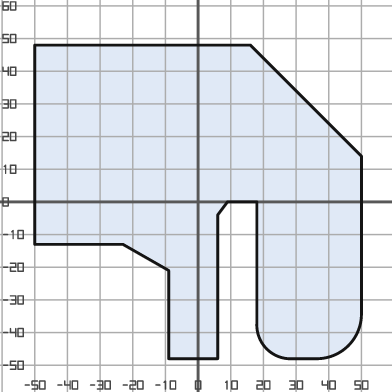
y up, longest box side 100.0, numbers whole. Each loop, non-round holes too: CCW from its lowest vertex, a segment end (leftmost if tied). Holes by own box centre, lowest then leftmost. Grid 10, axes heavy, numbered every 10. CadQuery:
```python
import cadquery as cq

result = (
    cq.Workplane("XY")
    .moveTo(-9.0, -48.0)
    .lineTo(6.0, -48.0)
    .lineTo(6.0, -4.0)
    .lineTo(9.0, 0.0)
    .lineTo(18.0, 0.0)
    .lineTo(18.0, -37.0)
    .threePointArc((21.0, -45.0), (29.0, -48.0))
    .lineTo(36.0, -48.0)
    .threePointArc((46.0, -44.0), (50.0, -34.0))
    .lineTo(50.0, 14.0)
    .lineTo(16.0, 48.0)
    .lineTo(-50.0, 48.0)
    .lineTo(-50.0, -13.0)
    .lineTo(-23.0, -13.0)
    .lineTo(-9.0, -21.0)
    .close()
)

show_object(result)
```